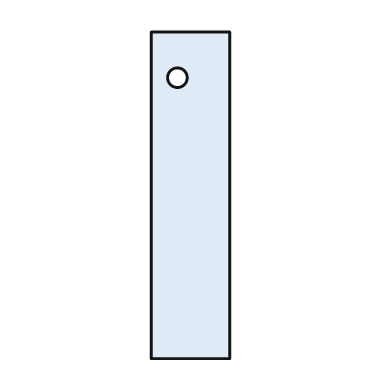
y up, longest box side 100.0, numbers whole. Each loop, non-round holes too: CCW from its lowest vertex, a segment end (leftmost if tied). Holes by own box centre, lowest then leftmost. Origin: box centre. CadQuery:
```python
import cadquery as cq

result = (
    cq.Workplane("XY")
    .moveTo(-12.0, -50.0)
    .lineTo(12.0, -50.0)
    .lineTo(12.0, 50.0)
    .lineTo(-12.0, 50.0)
    .close()
    .moveTo(-4.0, 36.0)
    .circle(3.0)
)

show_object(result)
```